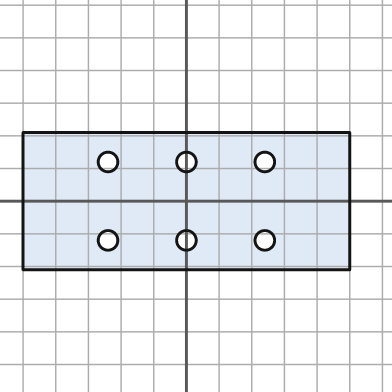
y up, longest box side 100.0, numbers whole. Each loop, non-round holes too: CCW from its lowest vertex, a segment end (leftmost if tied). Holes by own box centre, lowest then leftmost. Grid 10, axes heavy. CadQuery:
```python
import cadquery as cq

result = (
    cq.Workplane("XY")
    .moveTo(-50.0, -21.0)
    .lineTo(50.0, -21.0)
    .lineTo(50.0, 21.0)
    .lineTo(-50.0, 21.0)
    .close()
    .moveTo(-24.0, -12.0)
    .circle(3.0)
    .moveTo(0.0, -12.0)
    .circle(3.0)
    .moveTo(24.0, -12.0)
    .circle(3.0)
    .moveTo(-24.0, 12.0)
    .circle(3.0)
    .moveTo(0.0, 12.0)
    .circle(3.0)
    .moveTo(24.0, 12.0)
    .circle(3.0)
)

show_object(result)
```